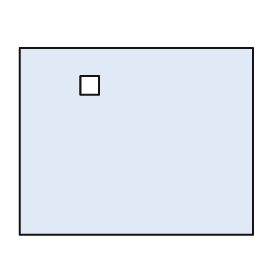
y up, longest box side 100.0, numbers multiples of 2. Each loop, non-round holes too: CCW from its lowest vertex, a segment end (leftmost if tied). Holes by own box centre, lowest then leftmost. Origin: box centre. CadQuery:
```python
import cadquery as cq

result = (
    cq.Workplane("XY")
    .moveTo(-50.0, -40.0)
    .lineTo(50.0, -40.0)
    .lineTo(50.0, 40.0)
    .lineTo(-50.0, 40.0)
    .close()
    .moveTo(-24.0, 20.0)
    .lineTo(-16.0, 20.0)
    .lineTo(-16.0, 28.0)
    .lineTo(-24.0, 28.0)
    .close()
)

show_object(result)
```